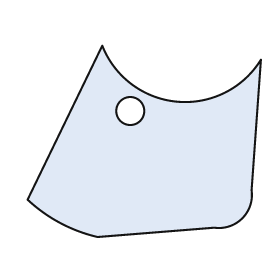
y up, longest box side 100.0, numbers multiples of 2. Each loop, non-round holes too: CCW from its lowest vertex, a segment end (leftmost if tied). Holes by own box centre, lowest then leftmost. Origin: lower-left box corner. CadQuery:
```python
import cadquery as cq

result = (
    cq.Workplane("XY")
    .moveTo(30.0, 0.0)
    .lineTo(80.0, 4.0)
    .threePointArc((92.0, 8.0), (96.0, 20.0))
    .lineTo(100.0, 76.0)
    .threePointArc((64.0, 58.0), (32.0, 82.0))
    .lineTo(0.0, 16.0)
    .threePointArc((14.0, 6.0), (30.0, 0.0))
    .close()
    .moveTo(44.0, 54.0)
    .circle(6.0)
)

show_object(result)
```